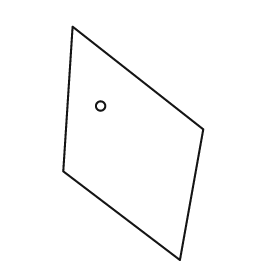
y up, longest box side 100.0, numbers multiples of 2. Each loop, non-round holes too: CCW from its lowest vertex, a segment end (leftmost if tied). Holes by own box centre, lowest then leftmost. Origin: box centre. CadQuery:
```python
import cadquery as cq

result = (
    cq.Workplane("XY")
    .moveTo(20.0, -50.0)
    .lineTo(30.0, 6.0)
    .lineTo(-26.0, 50.0)
    .lineTo(-30.0, -12.0)
    .close()
    .moveTo(-14.0, 16.0)
    .circle(2.0)
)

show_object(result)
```